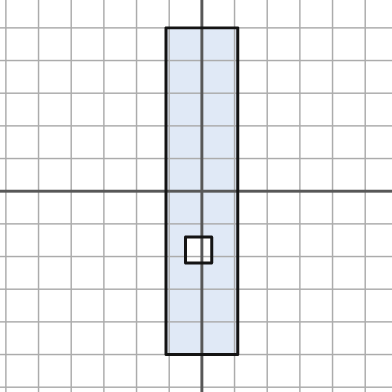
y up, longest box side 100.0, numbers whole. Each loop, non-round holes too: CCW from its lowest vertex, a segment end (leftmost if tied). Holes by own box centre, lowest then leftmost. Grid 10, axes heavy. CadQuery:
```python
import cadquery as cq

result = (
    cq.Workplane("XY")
    .moveTo(-11.0, -50.0)
    .lineTo(11.0, -50.0)
    .lineTo(11.0, 50.0)
    .lineTo(-11.0, 50.0)
    .close()
    .moveTo(-5.0, -22.0)
    .lineTo(3.0, -22.0)
    .lineTo(3.0, -14.0)
    .lineTo(-5.0, -14.0)
    .close()
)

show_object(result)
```